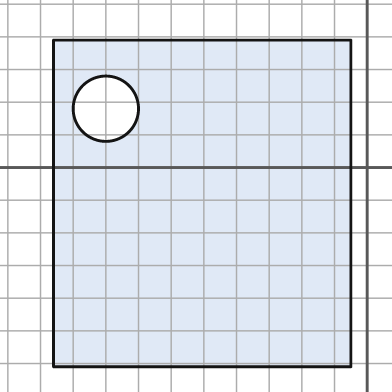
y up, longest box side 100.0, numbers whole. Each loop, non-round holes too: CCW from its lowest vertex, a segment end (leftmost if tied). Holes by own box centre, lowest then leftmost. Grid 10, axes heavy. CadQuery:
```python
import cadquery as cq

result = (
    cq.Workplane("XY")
    .moveTo(-96.0, -61.0)
    .lineTo(-5.0, -61.0)
    .lineTo(-5.0, 39.0)
    .lineTo(-96.0, 39.0)
    .close()
    .moveTo(-80.0, 18.0)
    .circle(10.0)
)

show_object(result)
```